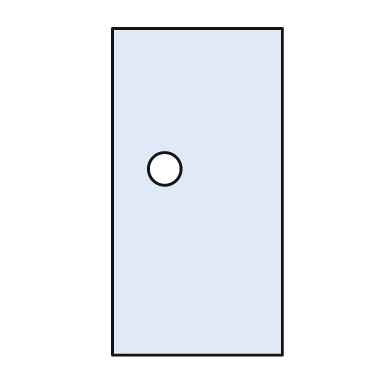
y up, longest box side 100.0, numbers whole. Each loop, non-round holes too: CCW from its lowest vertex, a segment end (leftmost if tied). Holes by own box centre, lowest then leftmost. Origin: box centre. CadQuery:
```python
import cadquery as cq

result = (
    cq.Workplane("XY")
    .moveTo(-26.0, -50.0)
    .lineTo(26.0, -50.0)
    .lineTo(26.0, 50.0)
    .lineTo(-26.0, 50.0)
    .close()
    .moveTo(-10.0, 7.0)
    .circle(5.0)
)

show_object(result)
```